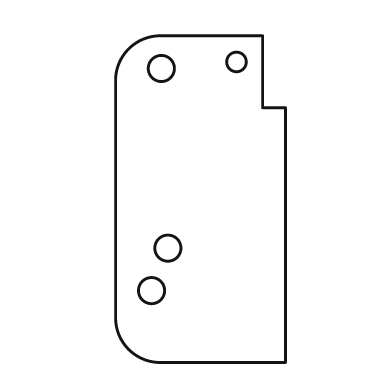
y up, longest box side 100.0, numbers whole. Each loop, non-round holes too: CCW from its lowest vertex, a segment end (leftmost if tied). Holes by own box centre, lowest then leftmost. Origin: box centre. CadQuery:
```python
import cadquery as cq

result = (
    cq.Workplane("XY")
    .moveTo(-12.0, -50.0)
    .lineTo(26.0, -50.0)
    .lineTo(26.0, 28.0)
    .lineTo(19.0, 28.0)
    .lineTo(19.0, 50.0)
    .lineTo(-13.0, 50.0)
    .threePointArc((-22.0, 46.0), (-26.0, 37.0))
    .lineTo(-26.0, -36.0)
    .threePointArc((-22.0, -46.0), (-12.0, -50.0))
    .close()
    .moveTo(-15.0, -28.0)
    .circle(4.0)
    .moveTo(-10.0, -15.0)
    .circle(4.0)
    .moveTo(-12.0, 40.0)
    .circle(4.0)
    .moveTo(11.0, 42.0)
    .circle(3.0)
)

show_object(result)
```